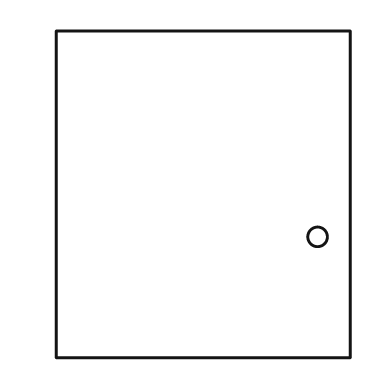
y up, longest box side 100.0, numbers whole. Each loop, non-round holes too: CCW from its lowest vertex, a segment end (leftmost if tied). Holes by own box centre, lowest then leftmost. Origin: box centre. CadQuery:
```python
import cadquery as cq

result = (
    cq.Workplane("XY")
    .moveTo(-45.0, -50.0)
    .lineTo(45.0, -50.0)
    .lineTo(45.0, 50.0)
    .lineTo(-45.0, 50.0)
    .close()
    .moveTo(35.0, -13.0)
    .circle(3.0)
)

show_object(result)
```